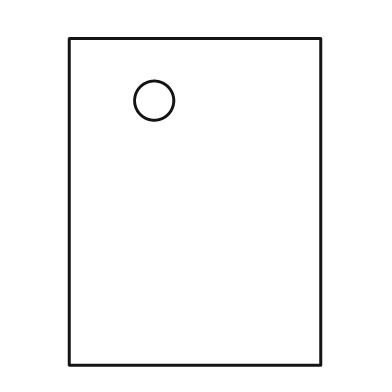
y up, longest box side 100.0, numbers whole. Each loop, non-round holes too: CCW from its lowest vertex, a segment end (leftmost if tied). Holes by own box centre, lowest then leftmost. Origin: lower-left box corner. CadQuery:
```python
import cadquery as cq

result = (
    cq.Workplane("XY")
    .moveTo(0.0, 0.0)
    .lineTo(77.0, 0.0)
    .lineTo(77.0, 100.0)
    .lineTo(0.0, 100.0)
    .close()
    .moveTo(26.0, 81.0)
    .circle(6.0)
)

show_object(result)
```